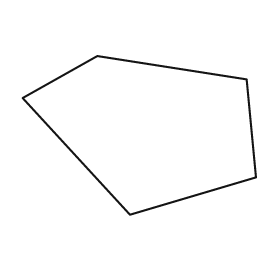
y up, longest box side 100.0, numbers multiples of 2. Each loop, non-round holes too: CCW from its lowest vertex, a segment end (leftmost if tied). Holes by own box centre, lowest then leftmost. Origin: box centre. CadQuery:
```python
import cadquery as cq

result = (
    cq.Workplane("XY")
    .moveTo(-4.0, -34.0)
    .lineTo(50.0, -18.0)
    .lineTo(46.0, 24.0)
    .lineTo(-18.0, 34.0)
    .lineTo(-50.0, 16.0)
    .close()
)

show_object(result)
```